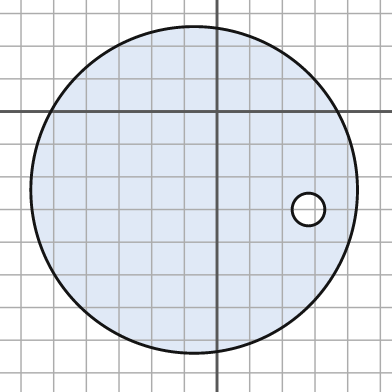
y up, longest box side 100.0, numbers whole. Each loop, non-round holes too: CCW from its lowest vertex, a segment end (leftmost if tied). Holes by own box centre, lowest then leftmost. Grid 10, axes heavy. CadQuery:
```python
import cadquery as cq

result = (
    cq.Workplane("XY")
    .moveTo(-7.0, -24.0)
    .circle(50.0)
    .moveTo(28.0, -30.0)
    .circle(5.0)
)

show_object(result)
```